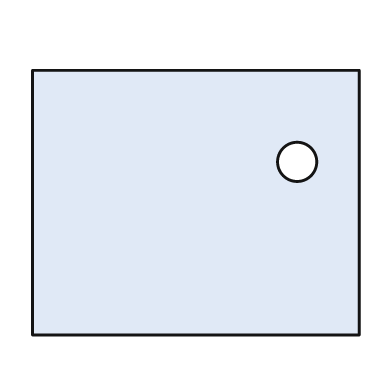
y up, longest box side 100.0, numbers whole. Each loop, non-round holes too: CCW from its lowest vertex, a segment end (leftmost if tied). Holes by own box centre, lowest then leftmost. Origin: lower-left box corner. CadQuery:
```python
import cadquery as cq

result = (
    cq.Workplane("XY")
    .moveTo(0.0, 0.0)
    .lineTo(100.0, 0.0)
    .lineTo(100.0, 81.0)
    .lineTo(0.0, 81.0)
    .close()
    .moveTo(81.0, 53.0)
    .circle(6.0)
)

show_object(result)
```